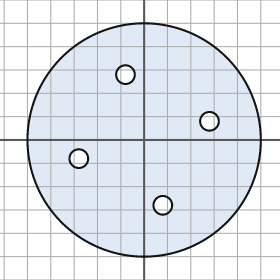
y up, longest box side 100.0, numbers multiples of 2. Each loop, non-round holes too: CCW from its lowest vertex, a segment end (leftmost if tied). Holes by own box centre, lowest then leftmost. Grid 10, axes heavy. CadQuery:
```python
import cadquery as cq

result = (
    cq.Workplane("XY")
    .moveTo(0.0, 0.0)
    .circle(50.0)
    .moveTo(8.0, -28.0)
    .circle(4.0)
    .moveTo(-28.0, -8.0)
    .circle(4.0)
    .moveTo(28.0, 8.0)
    .circle(4.0)
    .moveTo(-8.0, 28.0)
    .circle(4.0)
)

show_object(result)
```